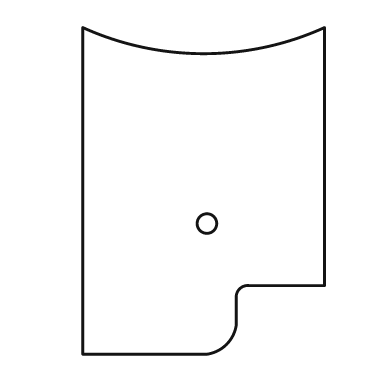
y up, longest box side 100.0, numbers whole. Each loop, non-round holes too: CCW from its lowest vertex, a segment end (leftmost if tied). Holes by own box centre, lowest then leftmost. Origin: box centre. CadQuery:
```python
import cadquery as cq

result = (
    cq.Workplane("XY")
    .moveTo(-37.0, -50.0)
    .lineTo(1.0, -50.0)
    .threePointArc((7.0, -47.0), (10.0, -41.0))
    .lineTo(10.0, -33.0)
    .threePointArc((11.0, -30.0), (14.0, -29.0))
    .lineTo(37.0, -29.0)
    .lineTo(37.0, 50.0)
    .threePointArc((0.0, 42.0), (-37.0, 50.0))
    .close()
    .moveTo(1.0, -10.0)
    .circle(3.0)
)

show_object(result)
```